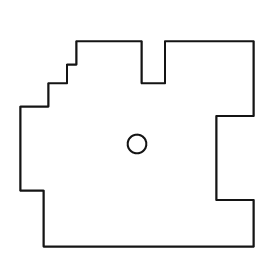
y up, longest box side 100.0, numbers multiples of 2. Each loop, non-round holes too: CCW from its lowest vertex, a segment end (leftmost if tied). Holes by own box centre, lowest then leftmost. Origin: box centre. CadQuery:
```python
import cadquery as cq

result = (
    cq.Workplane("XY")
    .moveTo(-40.0, -44.0)
    .lineTo(50.0, -44.0)
    .lineTo(50.0, -24.0)
    .lineTo(34.0, -24.0)
    .lineTo(34.0, 12.0)
    .lineTo(50.0, 12.0)
    .lineTo(50.0, 44.0)
    .lineTo(12.0, 44.0)
    .lineTo(12.0, 26.0)
    .lineTo(2.0, 26.0)
    .lineTo(2.0, 44.0)
    .lineTo(-26.0, 44.0)
    .lineTo(-26.0, 34.0)
    .lineTo(-30.0, 34.0)
    .lineTo(-30.0, 26.0)
    .lineTo(-38.0, 26.0)
    .lineTo(-38.0, 16.0)
    .lineTo(-50.0, 16.0)
    .lineTo(-50.0, -20.0)
    .lineTo(-40.0, -20.0)
    .close()
    .moveTo(0.0, 0.0)
    .circle(4.0)
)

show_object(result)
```